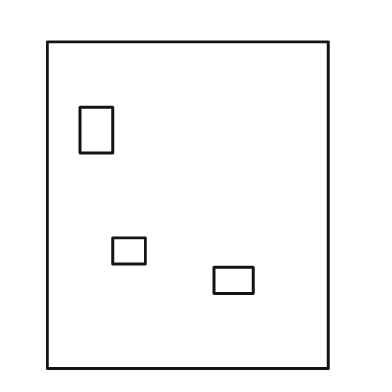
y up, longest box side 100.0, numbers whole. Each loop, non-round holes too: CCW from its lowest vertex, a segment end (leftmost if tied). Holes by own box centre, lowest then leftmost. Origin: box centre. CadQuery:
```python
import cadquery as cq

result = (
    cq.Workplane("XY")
    .moveTo(-43.0, -50.0)
    .lineTo(43.0, -50.0)
    .lineTo(43.0, 50.0)
    .lineTo(-43.0, 50.0)
    .close()
    .moveTo(8.0, -27.0)
    .lineTo(20.0, -27.0)
    .lineTo(20.0, -19.0)
    .lineTo(8.0, -19.0)
    .close()
    .moveTo(-23.0, -18.0)
    .lineTo(-13.0, -18.0)
    .lineTo(-13.0, -10.0)
    .lineTo(-23.0, -10.0)
    .close()
    .moveTo(-33.0, 16.0)
    .lineTo(-23.0, 16.0)
    .lineTo(-23.0, 30.0)
    .lineTo(-33.0, 30.0)
    .close()
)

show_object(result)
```